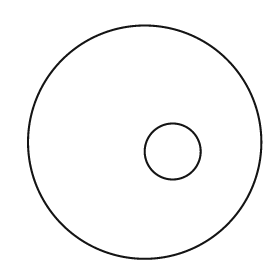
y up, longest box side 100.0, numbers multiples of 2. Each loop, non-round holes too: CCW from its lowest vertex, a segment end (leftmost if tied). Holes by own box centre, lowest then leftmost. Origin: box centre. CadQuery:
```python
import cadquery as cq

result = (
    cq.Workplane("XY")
    .moveTo(0.0, 0.0)
    .circle(50.0)
    .moveTo(12.0, -4.0)
    .circle(12.0)
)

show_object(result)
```